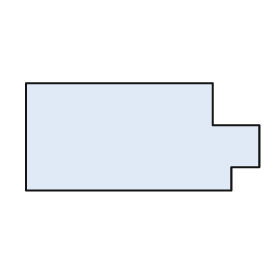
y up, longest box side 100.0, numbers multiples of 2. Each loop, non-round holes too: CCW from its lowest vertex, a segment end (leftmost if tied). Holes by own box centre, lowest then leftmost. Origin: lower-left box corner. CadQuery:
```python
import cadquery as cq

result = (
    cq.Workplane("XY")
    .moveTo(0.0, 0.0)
    .lineTo(88.0, 0.0)
    .lineTo(88.0, 10.0)
    .lineTo(100.0, 10.0)
    .lineTo(100.0, 28.0)
    .lineTo(80.0, 28.0)
    .lineTo(80.0, 46.0)
    .lineTo(0.0, 46.0)
    .close()
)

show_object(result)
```